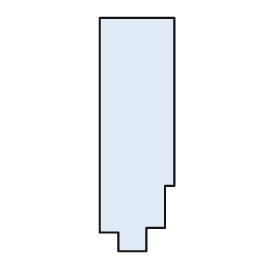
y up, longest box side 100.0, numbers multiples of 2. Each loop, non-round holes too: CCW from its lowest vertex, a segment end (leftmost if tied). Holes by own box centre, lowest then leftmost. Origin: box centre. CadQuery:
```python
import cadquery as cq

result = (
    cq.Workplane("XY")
    .moveTo(-8.0, -50.0)
    .lineTo(4.0, -50.0)
    .lineTo(4.0, -40.0)
    .lineTo(12.0, -40.0)
    .lineTo(12.0, -22.0)
    .lineTo(16.0, -22.0)
    .lineTo(16.0, 50.0)
    .lineTo(-16.0, 50.0)
    .lineTo(-16.0, -42.0)
    .lineTo(-8.0, -42.0)
    .close()
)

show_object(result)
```